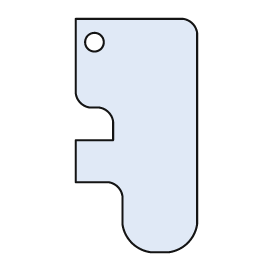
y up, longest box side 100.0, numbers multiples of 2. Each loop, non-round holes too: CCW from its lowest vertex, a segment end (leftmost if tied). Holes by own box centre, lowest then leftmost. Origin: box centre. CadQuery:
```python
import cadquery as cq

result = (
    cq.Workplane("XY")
    .moveTo(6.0, -50.0)
    .lineTo(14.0, -50.0)
    .threePointArc((22.0, -46.0), (26.0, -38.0))
    .lineTo(26.0, 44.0)
    .threePointArc((24.0, 48.0), (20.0, 50.0))
    .lineTo(-26.0, 50.0)
    .lineTo(-26.0, 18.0)
    .threePointArc((-24.0, 14.0), (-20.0, 12.0))
    .lineTo(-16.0, 12.0)
    .threePointArc((-12.0, 10.0), (-10.0, 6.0))
    .lineTo(-10.0, -2.0)
    .lineTo(-26.0, -2.0)
    .lineTo(-26.0, -20.0)
    .lineTo(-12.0, -20.0)
    .threePointArc((-8.0, -22.0), (-6.0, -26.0))
    .lineTo(-6.0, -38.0)
    .threePointArc((-2.0, -46.0), (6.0, -50.0))
    .close()
    .moveTo(-18.0, 40.0)
    .circle(4.0)
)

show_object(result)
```